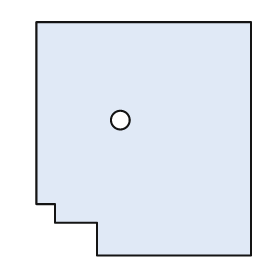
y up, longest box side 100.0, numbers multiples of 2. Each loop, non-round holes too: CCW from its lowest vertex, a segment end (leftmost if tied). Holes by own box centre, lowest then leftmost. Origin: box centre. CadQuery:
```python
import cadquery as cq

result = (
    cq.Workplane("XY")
    .moveTo(-20.0, -50.0)
    .lineTo(46.0, -50.0)
    .lineTo(46.0, 50.0)
    .lineTo(-46.0, 50.0)
    .lineTo(-46.0, -28.0)
    .lineTo(-38.0, -28.0)
    .lineTo(-38.0, -36.0)
    .lineTo(-20.0, -36.0)
    .close()
    .moveTo(-10.0, 8.0)
    .circle(4.0)
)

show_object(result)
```